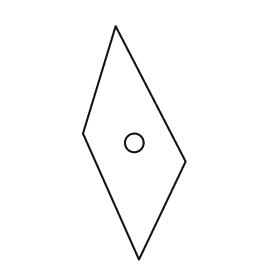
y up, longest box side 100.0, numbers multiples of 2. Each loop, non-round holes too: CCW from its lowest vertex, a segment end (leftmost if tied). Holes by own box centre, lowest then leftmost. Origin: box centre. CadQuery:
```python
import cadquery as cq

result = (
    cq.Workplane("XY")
    .moveTo(2.0, -50.0)
    .lineTo(22.0, -8.0)
    .lineTo(-8.0, 50.0)
    .lineTo(-22.0, 4.0)
    .close()
    .moveTo(0.0, 0.0)
    .circle(4.0)
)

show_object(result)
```